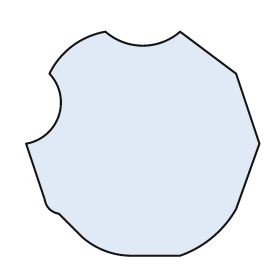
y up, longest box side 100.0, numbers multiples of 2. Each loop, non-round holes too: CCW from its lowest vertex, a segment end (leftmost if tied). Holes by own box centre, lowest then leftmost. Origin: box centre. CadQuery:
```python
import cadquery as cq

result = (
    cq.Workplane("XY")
    .moveTo(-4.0, -48.0)
    .lineTo(16.0, -48.0)
    .threePointArc((30.0, -40.0), (40.0, -28.0))
    .lineTo(50.0, 0.0)
    .lineTo(40.0, 30.0)
    .lineTo(16.0, 48.0)
    .threePointArc((0.0, 42.0), (-16.0, 48.0))
    .threePointArc((-30.0, 42.0), (-40.0, 30.0))
    .threePointArc((-36.0, 12.0), (-50.0, 0.0))
    .lineTo(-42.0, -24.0)
    .threePointArc((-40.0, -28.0), (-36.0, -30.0))
    .lineTo(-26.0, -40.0)
    .threePointArc((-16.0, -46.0), (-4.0, -48.0))
    .close()
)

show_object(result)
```